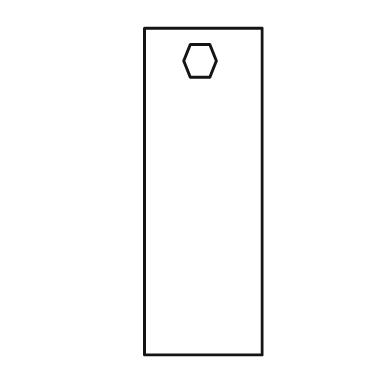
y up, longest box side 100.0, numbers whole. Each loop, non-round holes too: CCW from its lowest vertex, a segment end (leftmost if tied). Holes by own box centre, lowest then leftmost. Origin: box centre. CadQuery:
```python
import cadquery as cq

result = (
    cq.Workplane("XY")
    .moveTo(-18.0, -50.0)
    .lineTo(18.0, -50.0)
    .lineTo(18.0, 50.0)
    .lineTo(-18.0, 50.0)
    .close()
    .moveTo(-4.0, 35.0)
    .lineTo(2.0, 35.0)
    .lineTo(4.0, 40.0)
    .lineTo(2.0, 45.0)
    .lineTo(-4.0, 45.0)
    .lineTo(-6.0, 40.0)
    .close()
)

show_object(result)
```